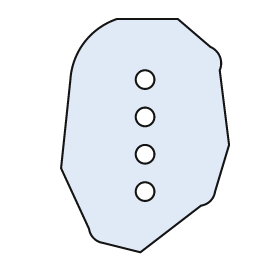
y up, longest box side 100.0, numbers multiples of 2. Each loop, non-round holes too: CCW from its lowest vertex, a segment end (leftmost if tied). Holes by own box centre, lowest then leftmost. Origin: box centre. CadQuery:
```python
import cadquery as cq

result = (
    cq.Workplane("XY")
    .moveTo(-2.0, -50.0)
    .lineTo(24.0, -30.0)
    .threePointArc((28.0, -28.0), (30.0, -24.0))
    .lineTo(36.0, -4.0)
    .lineTo(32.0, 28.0)
    .threePointArc((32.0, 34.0), (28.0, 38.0))
    .lineTo(14.0, 50.0)
    .lineTo(-12.0, 50.0)
    .threePointArc((-26.0, 40.0), (-32.0, 24.0))
    .lineTo(-36.0, -14.0)
    .lineTo(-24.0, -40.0)
    .threePointArc((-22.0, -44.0), (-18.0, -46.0))
    .close()
    .moveTo(0.0, -24.0)
    .circle(4.0)
    .moveTo(0.0, -8.0)
    .circle(4.0)
    .moveTo(0.0, 8.0)
    .circle(4.0)
    .moveTo(0.0, 24.0)
    .circle(4.0)
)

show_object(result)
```